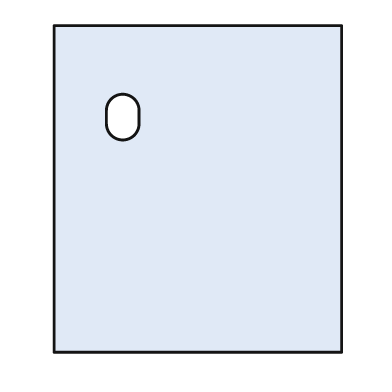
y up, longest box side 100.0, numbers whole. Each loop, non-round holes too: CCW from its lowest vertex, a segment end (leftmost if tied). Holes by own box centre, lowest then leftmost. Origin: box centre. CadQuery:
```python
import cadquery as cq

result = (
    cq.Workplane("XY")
    .moveTo(-44.0, -50.0)
    .lineTo(44.0, -50.0)
    .lineTo(44.0, 50.0)
    .lineTo(-44.0, 50.0)
    .close()
    .moveTo(-28.0, 20.0)
    .threePointArc((-23.0, 15.0), (-18.0, 20.0))
    .lineTo(-18.0, 24.0)
    .threePointArc((-23.0, 29.0), (-28.0, 24.0))
    .close()
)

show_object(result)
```